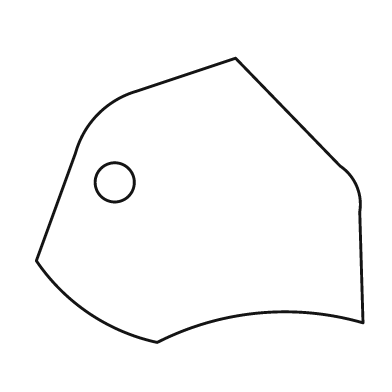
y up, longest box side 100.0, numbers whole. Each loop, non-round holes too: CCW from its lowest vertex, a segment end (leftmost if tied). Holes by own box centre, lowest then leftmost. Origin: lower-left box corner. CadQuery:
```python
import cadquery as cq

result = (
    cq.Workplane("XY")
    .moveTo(37.0, 0.0)
    .threePointArc((68.0, 9.0), (100.0, 6.0))
    .lineTo(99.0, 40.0)
    .threePointArc((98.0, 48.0), (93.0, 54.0))
    .lineTo(61.0, 87.0)
    .lineTo(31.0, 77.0)
    .threePointArc((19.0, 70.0), (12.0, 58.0))
    .lineTo(0.0, 25.0)
    .threePointArc((16.0, 9.0), (37.0, 0.0))
    .close()
    .moveTo(24.0, 49.0)
    .circle(6.0)
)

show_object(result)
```